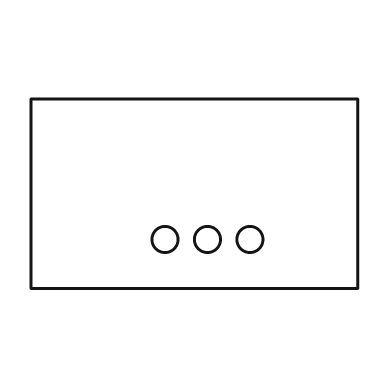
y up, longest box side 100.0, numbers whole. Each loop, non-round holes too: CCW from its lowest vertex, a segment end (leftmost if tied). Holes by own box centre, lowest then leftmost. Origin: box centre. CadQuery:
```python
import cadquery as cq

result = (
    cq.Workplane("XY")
    .moveTo(-50.0, -29.0)
    .lineTo(50.0, -29.0)
    .lineTo(50.0, 29.0)
    .lineTo(-50.0, 29.0)
    .close()
    .moveTo(-9.0, -14.0)
    .circle(4.0)
    .moveTo(4.0, -14.0)
    .circle(4.0)
    .moveTo(17.0, -14.0)
    .circle(4.0)
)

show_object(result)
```